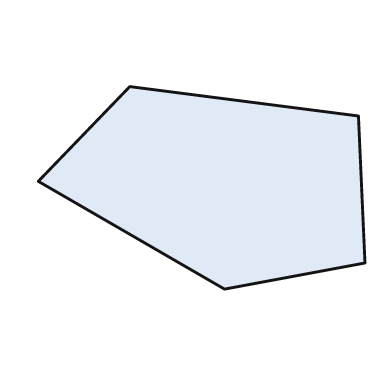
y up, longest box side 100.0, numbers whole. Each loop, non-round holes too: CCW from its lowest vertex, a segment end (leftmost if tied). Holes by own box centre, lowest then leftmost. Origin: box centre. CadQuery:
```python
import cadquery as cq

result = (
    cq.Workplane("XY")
    .moveTo(7.0, -31.0)
    .lineTo(50.0, -23.0)
    .lineTo(48.0, 22.0)
    .lineTo(-22.0, 31.0)
    .lineTo(-50.0, 2.0)
    .close()
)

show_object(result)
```